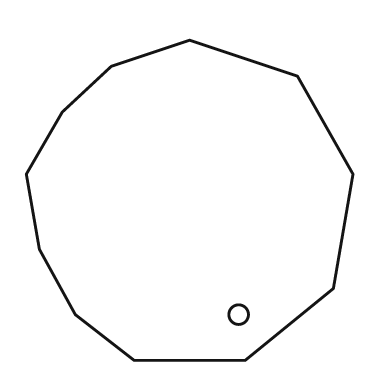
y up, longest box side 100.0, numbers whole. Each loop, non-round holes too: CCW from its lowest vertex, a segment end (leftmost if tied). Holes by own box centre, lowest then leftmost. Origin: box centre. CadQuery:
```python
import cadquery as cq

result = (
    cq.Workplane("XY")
    .moveTo(-17.0, -49.0)
    .lineTo(17.0, -49.0)
    .lineTo(44.0, -27.0)
    .lineTo(50.0, 8.0)
    .lineTo(33.0, 38.0)
    .lineTo(0.0, 49.0)
    .lineTo(-24.0, 41.0)
    .lineTo(-39.0, 27.0)
    .lineTo(-50.0, 8.0)
    .lineTo(-46.0, -15.0)
    .lineTo(-35.0, -35.0)
    .close()
    .moveTo(15.0, -35.0)
    .circle(3.0)
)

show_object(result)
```